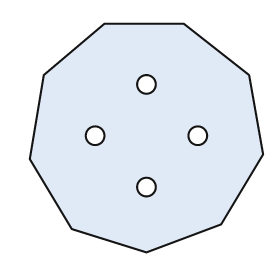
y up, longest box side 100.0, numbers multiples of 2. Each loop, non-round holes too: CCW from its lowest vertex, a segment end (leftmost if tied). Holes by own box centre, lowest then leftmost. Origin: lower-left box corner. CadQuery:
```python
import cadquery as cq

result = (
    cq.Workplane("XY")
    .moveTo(50.0, 0.0)
    .lineTo(82.0, 12.0)
    .lineTo(100.0, 42.0)
    .lineTo(94.0, 76.0)
    .lineTo(66.0, 98.0)
    .lineTo(32.0, 98.0)
    .lineTo(6.0, 76.0)
    .lineTo(0.0, 40.0)
    .lineTo(18.0, 10.0)
    .close()
    .moveTo(50.0, 28.0)
    .circle(4.0)
    .moveTo(28.0, 50.0)
    .circle(4.0)
    .moveTo(72.0, 50.0)
    .circle(4.0)
    .moveTo(50.0, 72.0)
    .circle(4.0)
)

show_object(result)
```